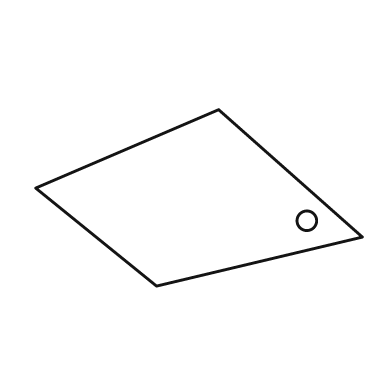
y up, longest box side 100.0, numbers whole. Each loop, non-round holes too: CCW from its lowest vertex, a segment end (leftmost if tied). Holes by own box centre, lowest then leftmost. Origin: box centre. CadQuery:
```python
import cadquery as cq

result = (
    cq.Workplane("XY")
    .moveTo(-13.0, -27.0)
    .lineTo(50.0, -12.0)
    .lineTo(6.0, 27.0)
    .lineTo(-50.0, 3.0)
    .close()
    .moveTo(33.0, -7.0)
    .circle(3.0)
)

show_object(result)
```